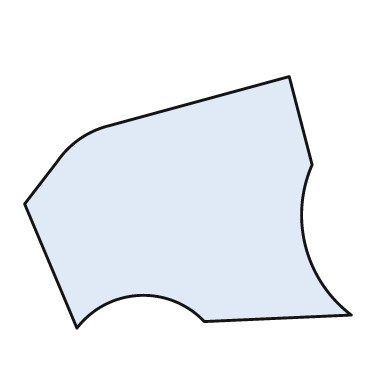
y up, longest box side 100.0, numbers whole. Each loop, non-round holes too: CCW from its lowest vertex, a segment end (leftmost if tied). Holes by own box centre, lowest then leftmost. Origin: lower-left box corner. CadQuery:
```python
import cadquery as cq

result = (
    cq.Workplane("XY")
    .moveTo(16.0, 0.0)
    .threePointArc((35.0, 10.0), (55.0, 2.0))
    .lineTo(100.0, 4.0)
    .threePointArc((86.0, 25.0), (88.0, 50.0))
    .lineTo(81.0, 77.0)
    .lineTo(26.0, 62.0)
    .threePointArc((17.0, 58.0), (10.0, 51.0))
    .lineTo(0.0, 38.0)
    .close()
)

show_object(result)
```